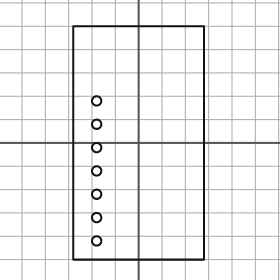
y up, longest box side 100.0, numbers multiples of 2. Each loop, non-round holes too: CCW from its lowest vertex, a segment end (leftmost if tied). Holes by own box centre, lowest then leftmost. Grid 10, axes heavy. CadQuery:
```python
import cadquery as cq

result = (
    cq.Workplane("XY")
    .moveTo(-28.0, -50.0)
    .lineTo(28.0, -50.0)
    .lineTo(28.0, 50.0)
    .lineTo(-28.0, 50.0)
    .close()
    .moveTo(-18.0, -42.0)
    .circle(2.0)
    .moveTo(-18.0, -32.0)
    .circle(2.0)
    .moveTo(-18.0, -22.0)
    .circle(2.0)
    .moveTo(-18.0, -12.0)
    .circle(2.0)
    .moveTo(-18.0, -2.0)
    .circle(2.0)
    .moveTo(-18.0, 8.0)
    .circle(2.0)
    .moveTo(-18.0, 18.0)
    .circle(2.0)
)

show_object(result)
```